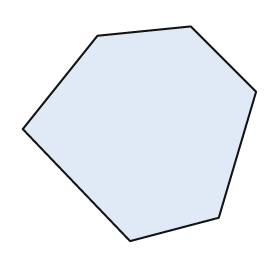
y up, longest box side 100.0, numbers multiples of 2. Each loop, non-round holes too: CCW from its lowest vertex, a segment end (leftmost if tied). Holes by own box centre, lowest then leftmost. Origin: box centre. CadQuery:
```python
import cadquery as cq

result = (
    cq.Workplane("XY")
    .moveTo(-4.0, -46.0)
    .lineTo(34.0, -36.0)
    .lineTo(50.0, 18.0)
    .lineTo(22.0, 46.0)
    .lineTo(-18.0, 42.0)
    .lineTo(-50.0, 2.0)
    .close()
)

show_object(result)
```